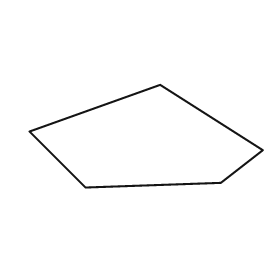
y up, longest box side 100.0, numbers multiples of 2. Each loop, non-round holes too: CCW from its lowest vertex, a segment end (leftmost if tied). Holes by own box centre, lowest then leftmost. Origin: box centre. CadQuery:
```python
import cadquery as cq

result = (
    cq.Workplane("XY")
    .moveTo(-26.0, -22.0)
    .lineTo(32.0, -20.0)
    .lineTo(50.0, -6.0)
    .lineTo(6.0, 22.0)
    .lineTo(-50.0, 2.0)
    .close()
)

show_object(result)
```